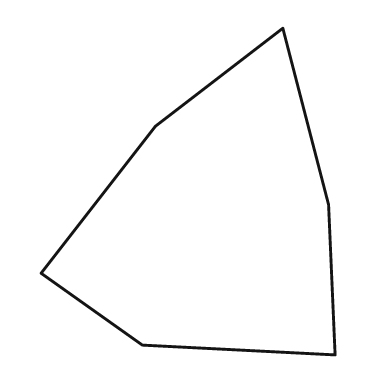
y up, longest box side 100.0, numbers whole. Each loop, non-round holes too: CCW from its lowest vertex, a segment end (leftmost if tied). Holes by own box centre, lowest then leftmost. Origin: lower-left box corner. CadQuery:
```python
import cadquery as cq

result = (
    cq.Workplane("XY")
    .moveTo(90.0, 0.0)
    .lineTo(88.0, 46.0)
    .lineTo(74.0, 100.0)
    .lineTo(35.0, 70.0)
    .lineTo(0.0, 25.0)
    .lineTo(31.0, 3.0)
    .close()
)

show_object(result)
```